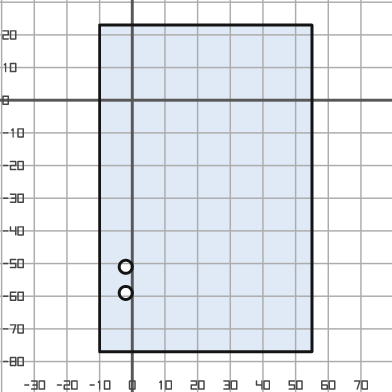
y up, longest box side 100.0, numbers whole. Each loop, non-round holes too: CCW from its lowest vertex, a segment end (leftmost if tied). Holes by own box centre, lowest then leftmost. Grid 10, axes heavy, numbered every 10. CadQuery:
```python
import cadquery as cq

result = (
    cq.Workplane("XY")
    .moveTo(-10.0, -77.0)
    .lineTo(55.0, -77.0)
    .lineTo(55.0, 23.0)
    .lineTo(-10.0, 23.0)
    .close()
    .moveTo(-2.0, -59.0)
    .circle(2.0)
    .moveTo(-2.0, -51.0)
    .circle(2.0)
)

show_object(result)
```